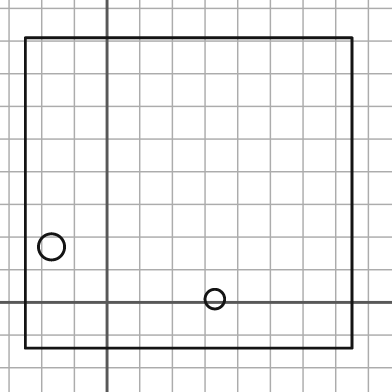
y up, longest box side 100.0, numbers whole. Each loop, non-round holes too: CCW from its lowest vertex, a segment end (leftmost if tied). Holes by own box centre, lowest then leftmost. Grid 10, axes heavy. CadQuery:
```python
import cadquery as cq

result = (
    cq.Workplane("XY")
    .moveTo(-25.0, -14.0)
    .lineTo(75.0, -14.0)
    .lineTo(75.0, 81.0)
    .lineTo(-25.0, 81.0)
    .close()
    .moveTo(33.0, 1.0)
    .circle(3.0)
    .moveTo(-17.0, 17.0)
    .circle(4.0)
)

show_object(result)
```